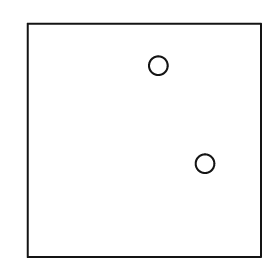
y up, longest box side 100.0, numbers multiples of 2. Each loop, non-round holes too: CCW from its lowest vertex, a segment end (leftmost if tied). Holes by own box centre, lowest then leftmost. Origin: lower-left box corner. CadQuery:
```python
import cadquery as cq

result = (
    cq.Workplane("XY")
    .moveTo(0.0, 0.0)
    .lineTo(100.0, 0.0)
    .lineTo(100.0, 100.0)
    .lineTo(0.0, 100.0)
    .close()
    .moveTo(76.0, 40.0)
    .circle(4.0)
    .moveTo(56.0, 82.0)
    .circle(4.0)
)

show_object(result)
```